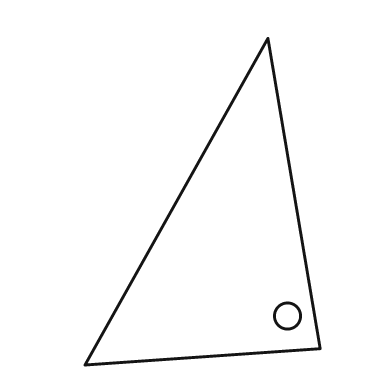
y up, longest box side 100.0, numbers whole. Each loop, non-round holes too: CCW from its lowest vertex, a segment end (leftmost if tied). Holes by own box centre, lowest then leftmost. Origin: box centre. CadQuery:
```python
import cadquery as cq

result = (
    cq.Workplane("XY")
    .moveTo(-36.0, -50.0)
    .lineTo(36.0, -45.0)
    .lineTo(20.0, 50.0)
    .close()
    .moveTo(26.0, -35.0)
    .circle(4.0)
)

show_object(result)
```